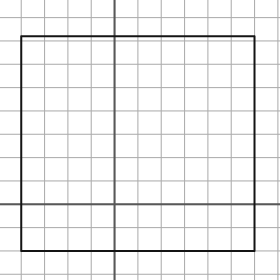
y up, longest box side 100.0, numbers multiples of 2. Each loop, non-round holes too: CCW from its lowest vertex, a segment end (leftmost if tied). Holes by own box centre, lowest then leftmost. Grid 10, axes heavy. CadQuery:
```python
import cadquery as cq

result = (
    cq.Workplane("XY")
    .moveTo(-40.0, -20.0)
    .lineTo(60.0, -20.0)
    .lineTo(60.0, 72.0)
    .lineTo(-40.0, 72.0)
    .close()
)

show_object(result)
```